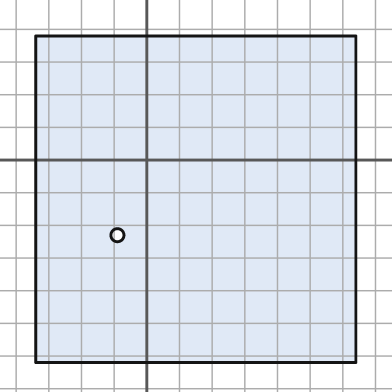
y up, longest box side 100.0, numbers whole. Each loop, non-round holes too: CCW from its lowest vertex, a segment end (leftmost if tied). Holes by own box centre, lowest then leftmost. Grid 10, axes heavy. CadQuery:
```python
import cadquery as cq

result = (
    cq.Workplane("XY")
    .moveTo(-34.0, -62.0)
    .lineTo(64.0, -62.0)
    .lineTo(64.0, 38.0)
    .lineTo(-34.0, 38.0)
    .close()
    .moveTo(-9.0, -23.0)
    .circle(2.0)
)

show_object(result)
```